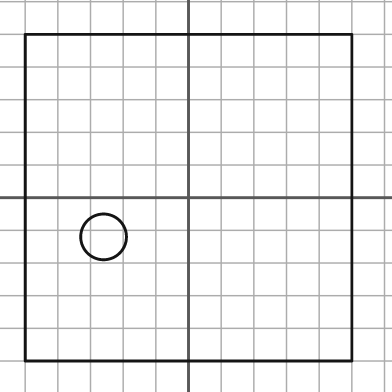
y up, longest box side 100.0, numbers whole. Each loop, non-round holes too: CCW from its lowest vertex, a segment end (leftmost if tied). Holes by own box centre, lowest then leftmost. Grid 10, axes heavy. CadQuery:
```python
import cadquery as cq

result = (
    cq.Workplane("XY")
    .moveTo(-50.0, -50.0)
    .lineTo(50.0, -50.0)
    .lineTo(50.0, 50.0)
    .lineTo(-50.0, 50.0)
    .close()
    .moveTo(-26.0, -12.0)
    .circle(7.0)
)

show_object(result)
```